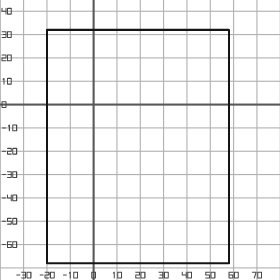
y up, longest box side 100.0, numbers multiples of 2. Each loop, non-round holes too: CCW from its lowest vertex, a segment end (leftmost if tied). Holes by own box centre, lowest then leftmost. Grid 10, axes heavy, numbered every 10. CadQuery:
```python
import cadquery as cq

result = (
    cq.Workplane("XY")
    .moveTo(-20.0, -68.0)
    .lineTo(58.0, -68.0)
    .lineTo(58.0, 32.0)
    .lineTo(-20.0, 32.0)
    .close()
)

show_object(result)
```